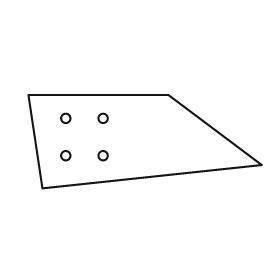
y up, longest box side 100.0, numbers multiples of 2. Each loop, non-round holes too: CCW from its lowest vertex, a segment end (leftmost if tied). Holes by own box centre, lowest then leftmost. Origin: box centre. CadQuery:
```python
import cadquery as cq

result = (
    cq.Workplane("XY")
    .moveTo(-44.0, -20.0)
    .lineTo(50.0, -10.0)
    .lineTo(10.0, 20.0)
    .lineTo(-50.0, 20.0)
    .close()
    .moveTo(-34.0, -6.0)
    .circle(2.0)
    .moveTo(-18.0, -6.0)
    .circle(2.0)
    .moveTo(-34.0, 10.0)
    .circle(2.0)
    .moveTo(-18.0, 10.0)
    .circle(2.0)
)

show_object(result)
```